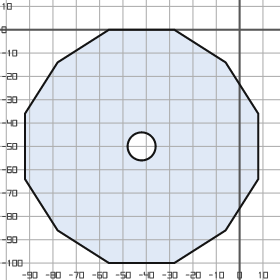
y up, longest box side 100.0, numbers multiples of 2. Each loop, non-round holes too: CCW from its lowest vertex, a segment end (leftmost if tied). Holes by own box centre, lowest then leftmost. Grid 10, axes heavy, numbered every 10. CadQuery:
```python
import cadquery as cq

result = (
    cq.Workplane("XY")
    .moveTo(-56.0, -100.0)
    .lineTo(-28.0, -100.0)
    .lineTo(-6.0, -86.0)
    .lineTo(8.0, -64.0)
    .lineTo(8.0, -36.0)
    .lineTo(-6.0, -14.0)
    .lineTo(-28.0, 0.0)
    .lineTo(-56.0, 0.0)
    .lineTo(-78.0, -14.0)
    .lineTo(-92.0, -36.0)
    .lineTo(-92.0, -64.0)
    .lineTo(-78.0, -86.0)
    .close()
    .moveTo(-42.0, -50.0)
    .circle(6.0)
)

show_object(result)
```